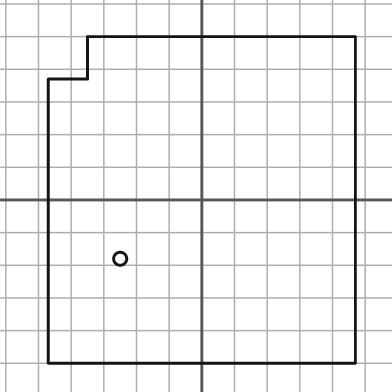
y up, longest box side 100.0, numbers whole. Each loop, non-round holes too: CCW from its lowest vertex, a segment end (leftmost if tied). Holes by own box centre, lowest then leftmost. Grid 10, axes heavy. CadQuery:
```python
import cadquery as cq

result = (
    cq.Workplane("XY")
    .moveTo(-47.0, -50.0)
    .lineTo(47.0, -50.0)
    .lineTo(47.0, 50.0)
    .lineTo(-35.0, 50.0)
    .lineTo(-35.0, 37.0)
    .lineTo(-47.0, 37.0)
    .close()
    .moveTo(-25.0, -18.0)
    .circle(2.0)
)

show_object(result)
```